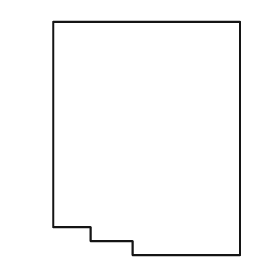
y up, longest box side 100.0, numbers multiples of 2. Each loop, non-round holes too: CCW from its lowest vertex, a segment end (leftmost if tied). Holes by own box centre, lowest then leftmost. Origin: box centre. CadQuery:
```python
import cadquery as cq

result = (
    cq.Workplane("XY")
    .moveTo(-6.0, -50.0)
    .lineTo(40.0, -50.0)
    .lineTo(40.0, 50.0)
    .lineTo(-40.0, 50.0)
    .lineTo(-40.0, -38.0)
    .lineTo(-24.0, -38.0)
    .lineTo(-24.0, -44.0)
    .lineTo(-6.0, -44.0)
    .close()
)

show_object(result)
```